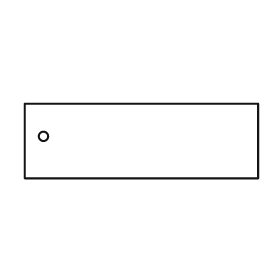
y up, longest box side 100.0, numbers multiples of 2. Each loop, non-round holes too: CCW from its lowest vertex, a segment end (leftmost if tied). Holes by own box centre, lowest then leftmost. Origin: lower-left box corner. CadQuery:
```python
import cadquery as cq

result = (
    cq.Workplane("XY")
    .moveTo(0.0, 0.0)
    .lineTo(100.0, 0.0)
    .lineTo(100.0, 32.0)
    .lineTo(0.0, 32.0)
    .close()
    .moveTo(8.0, 18.0)
    .circle(2.0)
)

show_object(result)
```